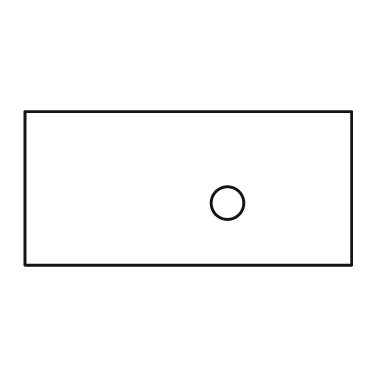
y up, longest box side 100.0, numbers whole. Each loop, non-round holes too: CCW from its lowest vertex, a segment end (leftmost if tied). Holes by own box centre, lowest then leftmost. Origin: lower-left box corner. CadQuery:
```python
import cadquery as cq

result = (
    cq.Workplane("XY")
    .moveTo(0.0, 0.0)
    .lineTo(100.0, 0.0)
    .lineTo(100.0, 47.0)
    .lineTo(0.0, 47.0)
    .close()
    .moveTo(62.0, 19.0)
    .circle(5.0)
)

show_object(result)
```